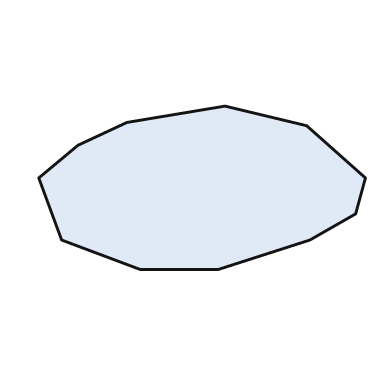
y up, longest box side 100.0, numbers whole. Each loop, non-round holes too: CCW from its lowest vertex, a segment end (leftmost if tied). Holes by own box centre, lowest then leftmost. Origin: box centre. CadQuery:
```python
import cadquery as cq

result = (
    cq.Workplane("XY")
    .moveTo(-19.0, -25.0)
    .lineTo(5.0, -25.0)
    .lineTo(33.0, -16.0)
    .lineTo(47.0, -8.0)
    .lineTo(50.0, 3.0)
    .lineTo(32.0, 19.0)
    .lineTo(7.0, 25.0)
    .lineTo(-23.0, 20.0)
    .lineTo(-38.0, 13.0)
    .lineTo(-50.0, 3.0)
    .lineTo(-43.0, -16.0)
    .close()
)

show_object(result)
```